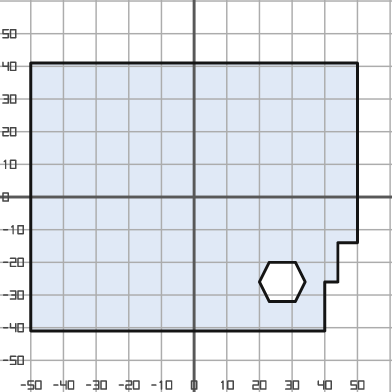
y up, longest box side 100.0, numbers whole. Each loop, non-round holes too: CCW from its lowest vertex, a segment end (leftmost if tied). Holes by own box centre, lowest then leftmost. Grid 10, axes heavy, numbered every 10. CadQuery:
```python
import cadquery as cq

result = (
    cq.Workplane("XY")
    .moveTo(-50.0, -41.0)
    .lineTo(40.0, -41.0)
    .lineTo(40.0, -26.0)
    .lineTo(44.0, -26.0)
    .lineTo(44.0, -14.0)
    .lineTo(50.0, -14.0)
    .lineTo(50.0, 41.0)
    .lineTo(-50.0, 41.0)
    .close()
    .moveTo(23.0, -32.0)
    .lineTo(31.0, -32.0)
    .lineTo(34.0, -26.0)
    .lineTo(31.0, -20.0)
    .lineTo(23.0, -20.0)
    .lineTo(20.0, -26.0)
    .close()
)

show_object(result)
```